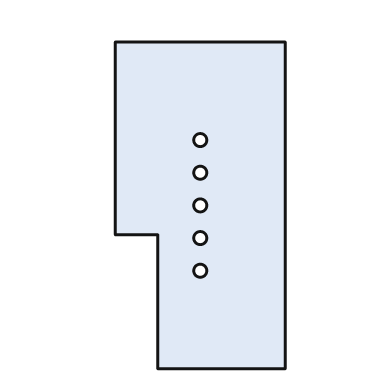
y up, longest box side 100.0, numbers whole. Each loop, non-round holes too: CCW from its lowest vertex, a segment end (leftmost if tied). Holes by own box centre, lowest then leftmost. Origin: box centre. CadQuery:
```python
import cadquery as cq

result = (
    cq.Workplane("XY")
    .moveTo(-13.0, -50.0)
    .lineTo(26.0, -50.0)
    .lineTo(26.0, 50.0)
    .lineTo(-26.0, 50.0)
    .lineTo(-26.0, -9.0)
    .lineTo(-13.0, -9.0)
    .close()
    .moveTo(0.0, -20.0)
    .circle(2.0)
    .moveTo(0.0, -10.0)
    .circle(2.0)
    .moveTo(0.0, 0.0)
    .circle(2.0)
    .moveTo(0.0, 10.0)
    .circle(2.0)
    .moveTo(0.0, 20.0)
    .circle(2.0)
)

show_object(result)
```